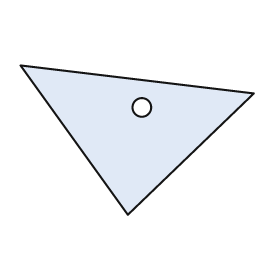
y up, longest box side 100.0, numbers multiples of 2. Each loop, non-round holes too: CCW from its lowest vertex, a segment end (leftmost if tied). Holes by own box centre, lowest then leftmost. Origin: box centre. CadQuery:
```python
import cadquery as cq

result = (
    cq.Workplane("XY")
    .moveTo(-4.0, -32.0)
    .lineTo(50.0, 20.0)
    .lineTo(-50.0, 32.0)
    .close()
    .moveTo(2.0, 14.0)
    .circle(4.0)
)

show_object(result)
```